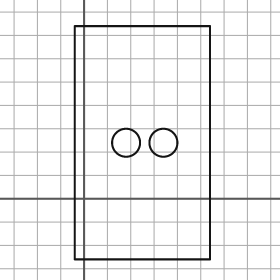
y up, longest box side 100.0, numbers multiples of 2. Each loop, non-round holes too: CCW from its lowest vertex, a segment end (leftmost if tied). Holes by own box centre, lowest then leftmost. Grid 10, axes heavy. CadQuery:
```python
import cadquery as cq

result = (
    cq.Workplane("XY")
    .moveTo(-4.0, -26.0)
    .lineTo(54.0, -26.0)
    .lineTo(54.0, 74.0)
    .lineTo(-4.0, 74.0)
    .close()
    .moveTo(18.0, 24.0)
    .circle(6.0)
    .moveTo(34.0, 24.0)
    .circle(6.0)
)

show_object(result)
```